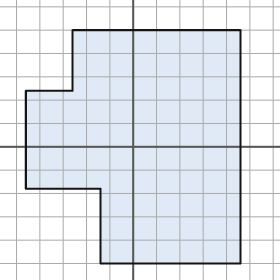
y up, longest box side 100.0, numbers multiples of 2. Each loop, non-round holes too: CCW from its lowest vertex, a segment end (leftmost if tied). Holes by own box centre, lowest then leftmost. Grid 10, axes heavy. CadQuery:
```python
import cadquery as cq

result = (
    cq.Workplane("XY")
    .moveTo(-14.0, -50.0)
    .lineTo(46.0, -50.0)
    .lineTo(46.0, 50.0)
    .lineTo(-26.0, 50.0)
    .lineTo(-26.0, 24.0)
    .lineTo(-46.0, 24.0)
    .lineTo(-46.0, -18.0)
    .lineTo(-14.0, -18.0)
    .close()
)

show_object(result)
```